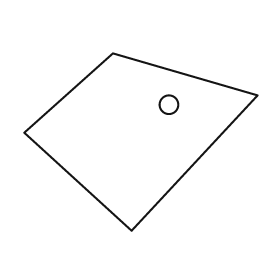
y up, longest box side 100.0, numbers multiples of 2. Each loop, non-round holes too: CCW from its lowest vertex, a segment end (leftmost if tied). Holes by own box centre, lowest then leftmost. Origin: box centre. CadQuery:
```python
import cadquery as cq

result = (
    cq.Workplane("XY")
    .moveTo(-4.0, -38.0)
    .lineTo(50.0, 20.0)
    .lineTo(-12.0, 38.0)
    .lineTo(-50.0, 4.0)
    .close()
    .moveTo(12.0, 16.0)
    .circle(4.0)
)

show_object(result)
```